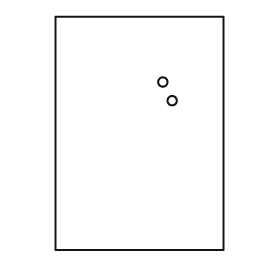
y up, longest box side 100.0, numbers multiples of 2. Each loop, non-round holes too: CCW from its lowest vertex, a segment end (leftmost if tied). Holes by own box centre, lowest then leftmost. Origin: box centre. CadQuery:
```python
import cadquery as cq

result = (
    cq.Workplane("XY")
    .moveTo(-36.0, -50.0)
    .lineTo(36.0, -50.0)
    .lineTo(36.0, 50.0)
    .lineTo(-36.0, 50.0)
    .close()
    .moveTo(14.0, 14.0)
    .circle(2.0)
    .moveTo(10.0, 22.0)
    .circle(2.0)
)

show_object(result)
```